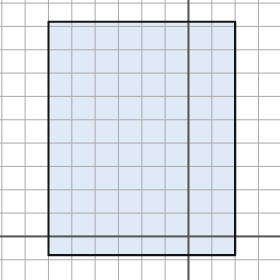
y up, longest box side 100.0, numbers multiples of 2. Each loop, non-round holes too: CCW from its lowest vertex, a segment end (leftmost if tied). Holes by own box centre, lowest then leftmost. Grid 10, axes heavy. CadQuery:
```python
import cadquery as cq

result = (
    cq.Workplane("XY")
    .moveTo(-60.0, -8.0)
    .lineTo(20.0, -8.0)
    .lineTo(20.0, 92.0)
    .lineTo(-60.0, 92.0)
    .close()
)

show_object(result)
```